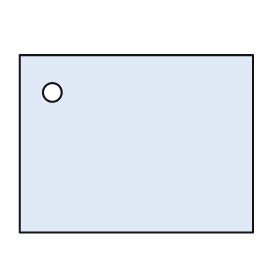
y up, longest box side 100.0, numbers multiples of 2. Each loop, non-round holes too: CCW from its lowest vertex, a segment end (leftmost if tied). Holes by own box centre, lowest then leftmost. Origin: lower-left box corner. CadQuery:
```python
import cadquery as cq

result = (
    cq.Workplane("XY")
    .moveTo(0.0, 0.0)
    .lineTo(100.0, 0.0)
    .lineTo(100.0, 76.0)
    .lineTo(0.0, 76.0)
    .close()
    .moveTo(14.0, 60.0)
    .circle(4.0)
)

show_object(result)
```